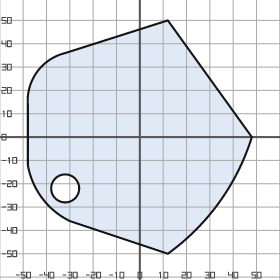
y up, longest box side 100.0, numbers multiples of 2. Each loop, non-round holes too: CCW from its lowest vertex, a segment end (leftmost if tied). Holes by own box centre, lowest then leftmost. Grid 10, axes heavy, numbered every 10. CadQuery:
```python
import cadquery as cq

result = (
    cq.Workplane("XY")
    .moveTo(12.0, -50.0)
    .threePointArc((34.0, -28.0), (48.0, 0.0))
    .lineTo(12.0, 50.0)
    .lineTo(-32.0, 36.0)
    .threePointArc((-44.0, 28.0), (-48.0, 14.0))
    .lineTo(-48.0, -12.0)
    .threePointArc((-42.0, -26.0), (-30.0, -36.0))
    .close()
    .moveTo(-32.0, -22.0)
    .circle(6.0)
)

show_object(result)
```